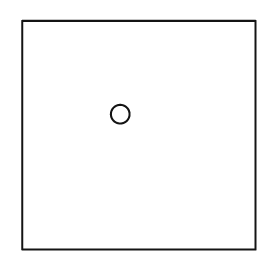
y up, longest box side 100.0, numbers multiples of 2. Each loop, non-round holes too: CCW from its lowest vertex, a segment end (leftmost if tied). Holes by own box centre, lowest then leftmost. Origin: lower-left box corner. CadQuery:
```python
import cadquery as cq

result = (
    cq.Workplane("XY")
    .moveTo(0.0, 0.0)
    .lineTo(100.0, 0.0)
    .lineTo(100.0, 98.0)
    .lineTo(0.0, 98.0)
    .close()
    .moveTo(42.0, 58.0)
    .circle(4.0)
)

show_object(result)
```